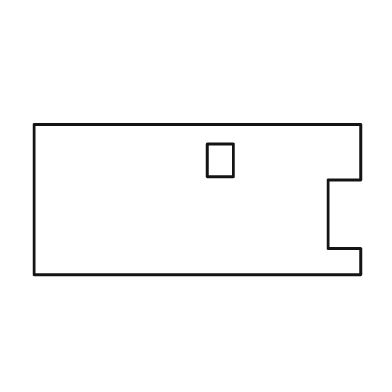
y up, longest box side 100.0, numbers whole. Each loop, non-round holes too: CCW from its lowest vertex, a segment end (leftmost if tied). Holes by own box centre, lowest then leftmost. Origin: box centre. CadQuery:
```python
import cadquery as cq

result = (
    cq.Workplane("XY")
    .moveTo(-50.0, -23.0)
    .lineTo(50.0, -23.0)
    .lineTo(50.0, -15.0)
    .lineTo(40.0, -15.0)
    .lineTo(40.0, 6.0)
    .lineTo(50.0, 6.0)
    .lineTo(50.0, 23.0)
    .lineTo(-50.0, 23.0)
    .close()
    .moveTo(3.0, 7.0)
    .lineTo(11.0, 7.0)
    .lineTo(11.0, 17.0)
    .lineTo(3.0, 17.0)
    .close()
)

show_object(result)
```